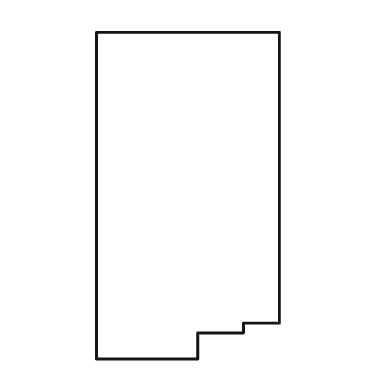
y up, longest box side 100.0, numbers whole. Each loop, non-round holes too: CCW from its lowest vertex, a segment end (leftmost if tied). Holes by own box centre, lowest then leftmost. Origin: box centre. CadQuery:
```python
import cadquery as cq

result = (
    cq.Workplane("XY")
    .moveTo(-28.0, -50.0)
    .lineTo(3.0, -50.0)
    .lineTo(3.0, -42.0)
    .lineTo(17.0, -42.0)
    .lineTo(17.0, -39.0)
    .lineTo(28.0, -39.0)
    .lineTo(28.0, 50.0)
    .lineTo(-28.0, 50.0)
    .close()
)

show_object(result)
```